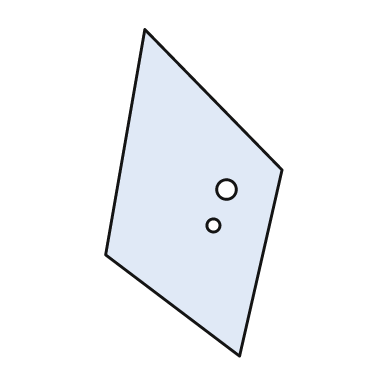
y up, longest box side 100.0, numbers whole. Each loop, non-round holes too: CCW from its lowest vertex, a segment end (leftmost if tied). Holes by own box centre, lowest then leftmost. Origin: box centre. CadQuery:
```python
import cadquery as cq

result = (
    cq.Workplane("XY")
    .moveTo(14.0, -50.0)
    .lineTo(27.0, 7.0)
    .lineTo(-15.0, 50.0)
    .lineTo(-27.0, -19.0)
    .close()
    .moveTo(6.0, -10.0)
    .circle(2.0)
    .moveTo(10.0, 1.0)
    .circle(3.0)
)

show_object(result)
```